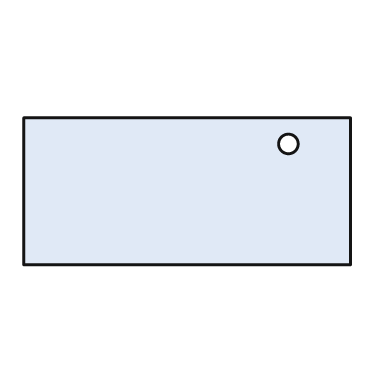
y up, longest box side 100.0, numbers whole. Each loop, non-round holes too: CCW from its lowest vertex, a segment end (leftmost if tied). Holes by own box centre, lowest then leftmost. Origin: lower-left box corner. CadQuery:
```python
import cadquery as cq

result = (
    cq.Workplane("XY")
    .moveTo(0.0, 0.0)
    .lineTo(100.0, 0.0)
    .lineTo(100.0, 45.0)
    .lineTo(0.0, 45.0)
    .close()
    .moveTo(81.0, 37.0)
    .circle(3.0)
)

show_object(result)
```